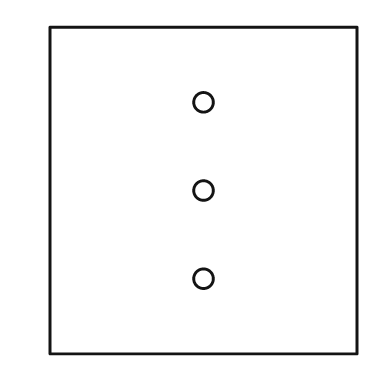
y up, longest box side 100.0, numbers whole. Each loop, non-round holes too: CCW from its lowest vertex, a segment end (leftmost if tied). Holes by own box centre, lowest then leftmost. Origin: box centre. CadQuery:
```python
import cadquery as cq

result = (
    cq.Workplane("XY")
    .moveTo(-47.0, -50.0)
    .lineTo(47.0, -50.0)
    .lineTo(47.0, 50.0)
    .lineTo(-47.0, 50.0)
    .close()
    .moveTo(0.0, -27.0)
    .circle(3.0)
    .moveTo(0.0, 0.0)
    .circle(3.0)
    .moveTo(0.0, 27.0)
    .circle(3.0)
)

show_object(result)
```